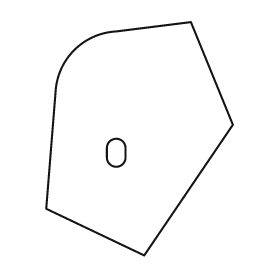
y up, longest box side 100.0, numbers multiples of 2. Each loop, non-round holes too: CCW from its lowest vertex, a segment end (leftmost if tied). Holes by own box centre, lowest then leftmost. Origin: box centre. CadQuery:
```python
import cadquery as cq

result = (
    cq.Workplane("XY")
    .moveTo(2.0, -50.0)
    .lineTo(40.0, 6.0)
    .lineTo(22.0, 50.0)
    .lineTo(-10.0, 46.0)
    .threePointArc((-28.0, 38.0), (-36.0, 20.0))
    .lineTo(-40.0, -30.0)
    .close()
    .moveTo(-14.0, -8.0)
    .threePointArc((-10.0, -12.0), (-6.0, -8.0))
    .lineTo(-6.0, -4.0)
    .threePointArc((-10.0, 0.0), (-14.0, -4.0))
    .close()
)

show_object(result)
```